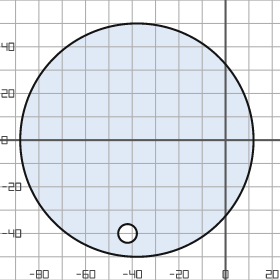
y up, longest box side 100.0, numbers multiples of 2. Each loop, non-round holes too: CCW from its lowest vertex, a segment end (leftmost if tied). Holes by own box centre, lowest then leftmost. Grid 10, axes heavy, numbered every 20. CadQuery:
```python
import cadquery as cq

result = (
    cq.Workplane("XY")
    .moveTo(-38.0, 0.0)
    .circle(50.0)
    .moveTo(-42.0, -40.0)
    .circle(4.0)
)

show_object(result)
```